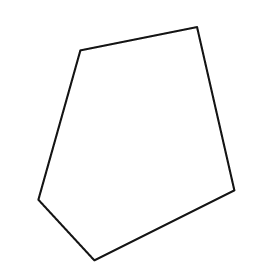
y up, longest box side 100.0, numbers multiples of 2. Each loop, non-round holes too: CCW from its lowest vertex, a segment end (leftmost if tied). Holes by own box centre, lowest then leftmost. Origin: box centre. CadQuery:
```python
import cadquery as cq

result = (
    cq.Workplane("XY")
    .moveTo(-18.0, -50.0)
    .lineTo(42.0, -20.0)
    .lineTo(26.0, 50.0)
    .lineTo(-24.0, 40.0)
    .lineTo(-42.0, -24.0)
    .close()
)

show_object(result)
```